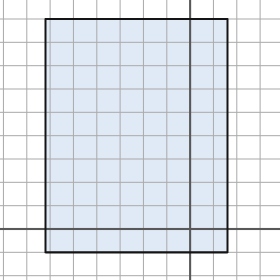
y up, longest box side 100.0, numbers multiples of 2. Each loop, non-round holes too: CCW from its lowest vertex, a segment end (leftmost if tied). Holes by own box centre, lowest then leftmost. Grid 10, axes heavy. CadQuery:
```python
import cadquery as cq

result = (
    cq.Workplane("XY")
    .moveTo(-62.0, -10.0)
    .lineTo(16.0, -10.0)
    .lineTo(16.0, 90.0)
    .lineTo(-62.0, 90.0)
    .close()
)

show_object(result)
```